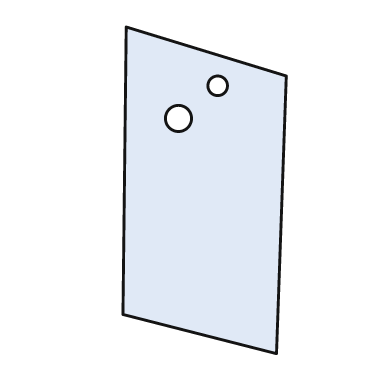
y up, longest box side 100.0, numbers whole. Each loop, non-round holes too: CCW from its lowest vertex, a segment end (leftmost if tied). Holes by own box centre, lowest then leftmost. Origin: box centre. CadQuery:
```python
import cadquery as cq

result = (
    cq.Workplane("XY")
    .moveTo(22.0, -50.0)
    .lineTo(25.0, 35.0)
    .lineTo(-24.0, 50.0)
    .lineTo(-25.0, -38.0)
    .close()
    .moveTo(-8.0, 22.0)
    .circle(4.0)
    .moveTo(4.0, 32.0)
    .circle(3.0)
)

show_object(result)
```